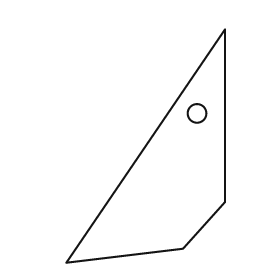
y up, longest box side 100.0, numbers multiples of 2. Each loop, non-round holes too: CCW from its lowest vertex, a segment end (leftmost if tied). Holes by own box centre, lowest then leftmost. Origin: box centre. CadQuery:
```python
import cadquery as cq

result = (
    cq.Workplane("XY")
    .moveTo(-34.0, -50.0)
    .lineTo(16.0, -44.0)
    .lineTo(34.0, -24.0)
    .lineTo(34.0, 50.0)
    .close()
    .moveTo(22.0, 14.0)
    .circle(4.0)
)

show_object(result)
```